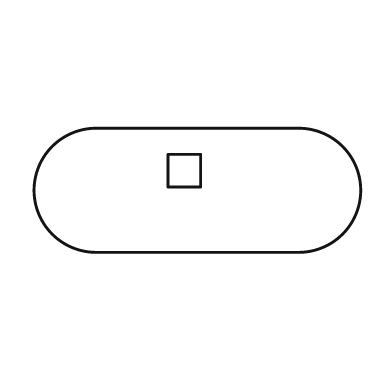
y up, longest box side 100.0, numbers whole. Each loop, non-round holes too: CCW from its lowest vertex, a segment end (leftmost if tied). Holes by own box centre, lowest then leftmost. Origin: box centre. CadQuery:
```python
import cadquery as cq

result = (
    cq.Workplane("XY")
    .moveTo(-31.0, -19.0)
    .lineTo(31.0, -19.0)
    .threePointArc((50.0, 0.0), (31.0, 19.0))
    .lineTo(-31.0, 19.0)
    .threePointArc((-50.0, 0.0), (-31.0, -19.0))
    .close()
    .moveTo(-9.0, 1.0)
    .lineTo(1.0, 1.0)
    .lineTo(1.0, 11.0)
    .lineTo(-9.0, 11.0)
    .close()
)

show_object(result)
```